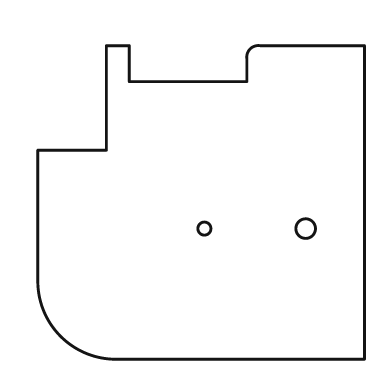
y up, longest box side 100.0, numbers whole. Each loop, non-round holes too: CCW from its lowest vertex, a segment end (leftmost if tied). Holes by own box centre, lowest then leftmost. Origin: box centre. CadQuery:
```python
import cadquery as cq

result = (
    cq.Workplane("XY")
    .moveTo(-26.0, -48.0)
    .lineTo(50.0, -48.0)
    .lineTo(50.0, 48.0)
    .lineTo(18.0, 48.0)
    .threePointArc((15.0, 47.0), (14.0, 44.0))
    .lineTo(14.0, 37.0)
    .lineTo(-22.0, 37.0)
    .lineTo(-22.0, 48.0)
    .lineTo(-29.0, 48.0)
    .lineTo(-29.0, 16.0)
    .lineTo(-50.0, 16.0)
    .lineTo(-50.0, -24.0)
    .threePointArc((-43.0, -41.0), (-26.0, -48.0))
    .close()
    .moveTo(1.0, -8.0)
    .circle(2.0)
    .moveTo(32.0, -8.0)
    .circle(3.0)
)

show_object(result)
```